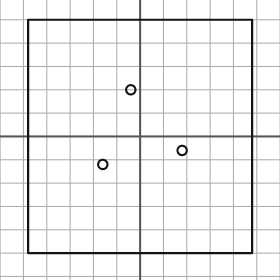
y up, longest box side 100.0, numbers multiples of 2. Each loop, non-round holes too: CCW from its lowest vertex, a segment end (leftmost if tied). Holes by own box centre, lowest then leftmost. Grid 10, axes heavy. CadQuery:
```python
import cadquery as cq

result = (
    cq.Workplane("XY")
    .moveTo(-48.0, -50.0)
    .lineTo(48.0, -50.0)
    .lineTo(48.0, 50.0)
    .lineTo(-48.0, 50.0)
    .close()
    .moveTo(-16.0, -12.0)
    .circle(2.0)
    .moveTo(18.0, -6.0)
    .circle(2.0)
    .moveTo(-4.0, 20.0)
    .circle(2.0)
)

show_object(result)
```